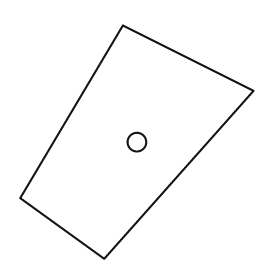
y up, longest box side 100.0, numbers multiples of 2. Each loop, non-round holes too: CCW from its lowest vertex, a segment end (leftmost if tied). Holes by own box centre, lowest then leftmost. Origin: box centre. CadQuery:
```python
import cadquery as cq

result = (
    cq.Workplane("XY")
    .moveTo(-14.0, -50.0)
    .lineTo(50.0, 22.0)
    .lineTo(-6.0, 50.0)
    .lineTo(-50.0, -24.0)
    .close()
    .moveTo(0.0, 0.0)
    .circle(4.0)
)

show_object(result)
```